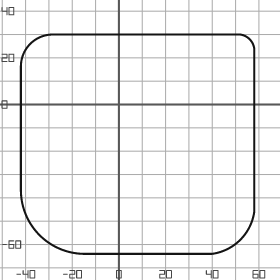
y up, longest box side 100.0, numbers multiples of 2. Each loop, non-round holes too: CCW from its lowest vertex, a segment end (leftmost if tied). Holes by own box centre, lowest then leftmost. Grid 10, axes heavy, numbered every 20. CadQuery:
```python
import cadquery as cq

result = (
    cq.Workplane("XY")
    .moveTo(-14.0, -64.0)
    .lineTo(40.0, -64.0)
    .threePointArc((52.0, -58.0), (58.0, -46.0))
    .lineTo(58.0, 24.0)
    .threePointArc((56.0, 28.0), (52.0, 30.0))
    .lineTo(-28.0, 30.0)
    .threePointArc((-38.0, 26.0), (-42.0, 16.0))
    .lineTo(-42.0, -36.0)
    .threePointArc((-34.0, -56.0), (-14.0, -64.0))
    .close()
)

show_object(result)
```